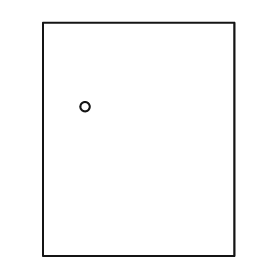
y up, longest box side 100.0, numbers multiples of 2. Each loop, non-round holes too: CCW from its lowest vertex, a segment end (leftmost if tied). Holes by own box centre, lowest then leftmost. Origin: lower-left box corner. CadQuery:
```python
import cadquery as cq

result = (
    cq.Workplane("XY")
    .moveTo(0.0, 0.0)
    .lineTo(82.0, 0.0)
    .lineTo(82.0, 100.0)
    .lineTo(0.0, 100.0)
    .close()
    .moveTo(18.0, 64.0)
    .circle(2.0)
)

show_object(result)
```